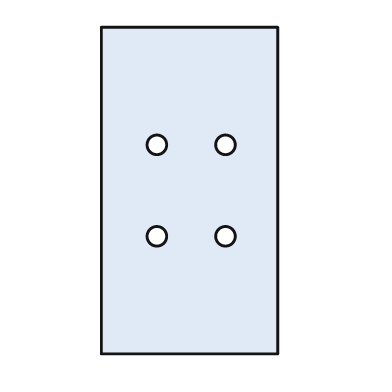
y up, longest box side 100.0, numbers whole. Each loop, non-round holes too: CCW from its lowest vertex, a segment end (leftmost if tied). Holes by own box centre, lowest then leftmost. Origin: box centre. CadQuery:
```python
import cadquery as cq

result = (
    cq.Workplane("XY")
    .moveTo(-27.0, -50.0)
    .lineTo(27.0, -50.0)
    .lineTo(27.0, 50.0)
    .lineTo(-27.0, 50.0)
    .close()
    .moveTo(-10.0, -14.0)
    .circle(3.0)
    .moveTo(11.0, -14.0)
    .circle(3.0)
    .moveTo(-10.0, 14.0)
    .circle(3.0)
    .moveTo(11.0, 14.0)
    .circle(3.0)
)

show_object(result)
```